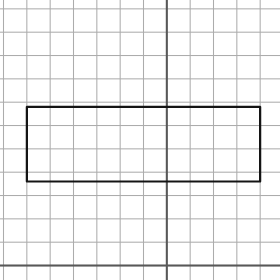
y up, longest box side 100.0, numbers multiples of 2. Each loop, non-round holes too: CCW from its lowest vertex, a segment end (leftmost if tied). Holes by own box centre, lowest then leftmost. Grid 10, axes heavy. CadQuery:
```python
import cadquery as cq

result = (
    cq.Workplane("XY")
    .moveTo(-60.0, 36.0)
    .lineTo(40.0, 36.0)
    .lineTo(40.0, 68.0)
    .lineTo(-60.0, 68.0)
    .close()
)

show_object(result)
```